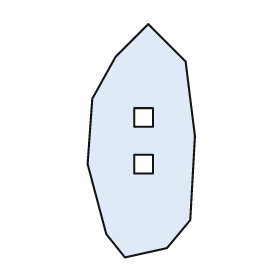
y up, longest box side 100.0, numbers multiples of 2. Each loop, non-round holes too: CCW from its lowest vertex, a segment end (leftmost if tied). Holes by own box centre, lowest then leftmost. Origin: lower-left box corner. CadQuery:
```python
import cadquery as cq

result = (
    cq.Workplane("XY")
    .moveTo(16.0, 0.0)
    .lineTo(34.0, 4.0)
    .lineTo(44.0, 16.0)
    .lineTo(46.0, 52.0)
    .lineTo(42.0, 84.0)
    .lineTo(26.0, 100.0)
    .lineTo(12.0, 86.0)
    .lineTo(2.0, 68.0)
    .lineTo(0.0, 40.0)
    .lineTo(8.0, 10.0)
    .close()
    .moveTo(20.0, 36.0)
    .lineTo(28.0, 36.0)
    .lineTo(28.0, 44.0)
    .lineTo(20.0, 44.0)
    .close()
    .moveTo(20.0, 56.0)
    .lineTo(28.0, 56.0)
    .lineTo(28.0, 64.0)
    .lineTo(20.0, 64.0)
    .close()
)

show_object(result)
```